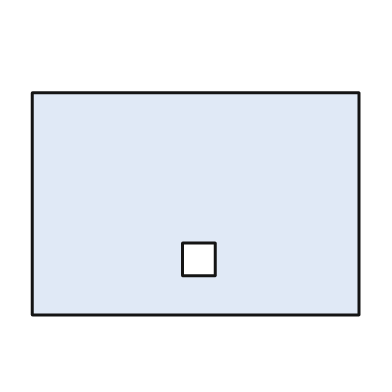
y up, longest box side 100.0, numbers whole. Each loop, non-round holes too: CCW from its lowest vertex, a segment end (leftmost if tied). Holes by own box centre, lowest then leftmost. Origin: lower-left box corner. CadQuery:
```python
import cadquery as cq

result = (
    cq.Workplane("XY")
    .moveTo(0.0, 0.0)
    .lineTo(100.0, 0.0)
    .lineTo(100.0, 68.0)
    .lineTo(0.0, 68.0)
    .close()
    .moveTo(46.0, 12.0)
    .lineTo(56.0, 12.0)
    .lineTo(56.0, 22.0)
    .lineTo(46.0, 22.0)
    .close()
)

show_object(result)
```